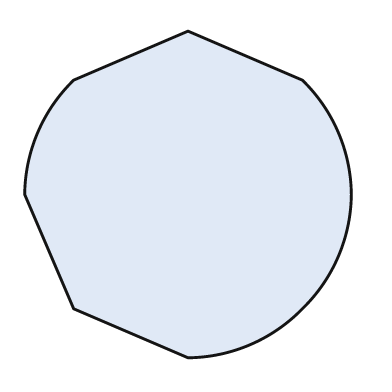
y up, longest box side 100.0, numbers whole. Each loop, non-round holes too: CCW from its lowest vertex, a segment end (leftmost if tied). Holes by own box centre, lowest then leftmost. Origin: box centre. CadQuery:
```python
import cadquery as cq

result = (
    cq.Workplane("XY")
    .moveTo(0.0, -50.0)
    .threePointArc((19.0, -46.0), (35.0, -35.0))
    .threePointArc((46.0, -19.0), (50.0, 0.0))
    .threePointArc((46.0, 19.0), (35.0, 35.0))
    .lineTo(0.0, 50.0)
    .lineTo(-35.0, 35.0)
    .threePointArc((-46.0, 19.0), (-50.0, 0.0))
    .lineTo(-35.0, -35.0)
    .close()
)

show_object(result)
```